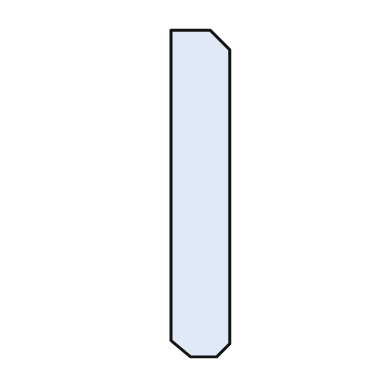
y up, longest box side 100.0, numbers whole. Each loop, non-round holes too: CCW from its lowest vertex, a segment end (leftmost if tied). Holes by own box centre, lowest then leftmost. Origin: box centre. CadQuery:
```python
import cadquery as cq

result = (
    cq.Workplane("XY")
    .moveTo(-3.0, -50.0)
    .lineTo(5.0, -50.0)
    .lineTo(9.0, -46.0)
    .lineTo(9.0, 44.0)
    .lineTo(3.0, 50.0)
    .lineTo(-9.0, 50.0)
    .lineTo(-9.0, -45.0)
    .close()
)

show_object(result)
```